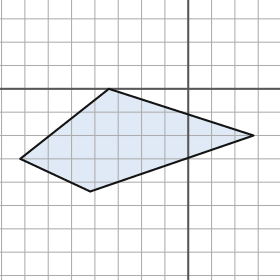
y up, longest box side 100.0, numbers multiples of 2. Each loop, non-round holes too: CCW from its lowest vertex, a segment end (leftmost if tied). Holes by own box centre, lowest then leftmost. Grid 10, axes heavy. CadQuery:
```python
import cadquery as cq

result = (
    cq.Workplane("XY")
    .moveTo(-42.0, -44.0)
    .lineTo(28.0, -20.0)
    .lineTo(-34.0, 0.0)
    .lineTo(-72.0, -30.0)
    .close()
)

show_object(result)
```